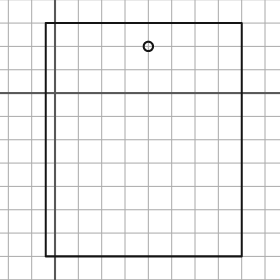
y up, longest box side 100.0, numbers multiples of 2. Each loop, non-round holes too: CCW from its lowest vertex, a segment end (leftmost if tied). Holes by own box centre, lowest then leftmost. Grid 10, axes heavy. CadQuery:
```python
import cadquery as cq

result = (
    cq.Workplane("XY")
    .moveTo(-4.0, -70.0)
    .lineTo(80.0, -70.0)
    .lineTo(80.0, 30.0)
    .lineTo(-4.0, 30.0)
    .close()
    .moveTo(40.0, 20.0)
    .circle(2.0)
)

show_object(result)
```